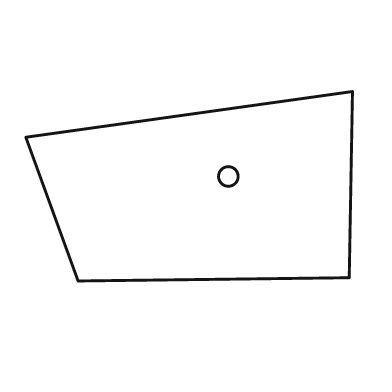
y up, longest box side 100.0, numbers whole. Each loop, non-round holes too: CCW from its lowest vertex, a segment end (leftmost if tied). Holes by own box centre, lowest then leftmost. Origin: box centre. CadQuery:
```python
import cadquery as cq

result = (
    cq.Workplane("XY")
    .moveTo(-34.0, -29.0)
    .lineTo(49.0, -28.0)
    .lineTo(50.0, 29.0)
    .lineTo(-50.0, 15.0)
    .close()
    .moveTo(12.0, 3.0)
    .circle(3.0)
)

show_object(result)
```